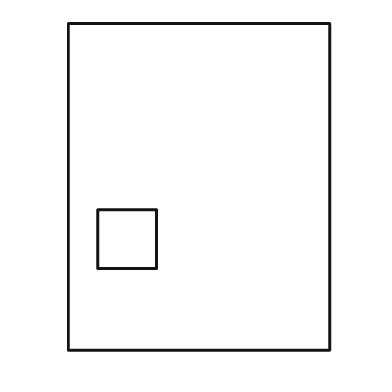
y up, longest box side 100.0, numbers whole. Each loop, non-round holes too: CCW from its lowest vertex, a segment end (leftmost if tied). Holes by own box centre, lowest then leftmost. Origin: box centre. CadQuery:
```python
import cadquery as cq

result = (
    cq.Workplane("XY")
    .moveTo(-40.0, -50.0)
    .lineTo(40.0, -50.0)
    .lineTo(40.0, 50.0)
    .lineTo(-40.0, 50.0)
    .close()
    .moveTo(-31.0, -25.0)
    .lineTo(-13.0, -25.0)
    .lineTo(-13.0, -7.0)
    .lineTo(-31.0, -7.0)
    .close()
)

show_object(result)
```